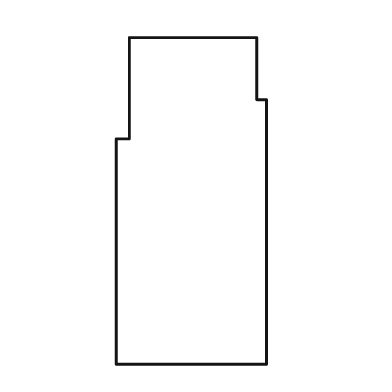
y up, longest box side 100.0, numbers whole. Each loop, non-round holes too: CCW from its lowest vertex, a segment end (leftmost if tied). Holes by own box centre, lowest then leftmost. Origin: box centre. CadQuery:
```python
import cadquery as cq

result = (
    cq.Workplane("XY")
    .moveTo(-23.0, -50.0)
    .lineTo(23.0, -50.0)
    .lineTo(23.0, 31.0)
    .lineTo(20.0, 31.0)
    .lineTo(20.0, 50.0)
    .lineTo(-19.0, 50.0)
    .lineTo(-19.0, 19.0)
    .lineTo(-23.0, 19.0)
    .close()
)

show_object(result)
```